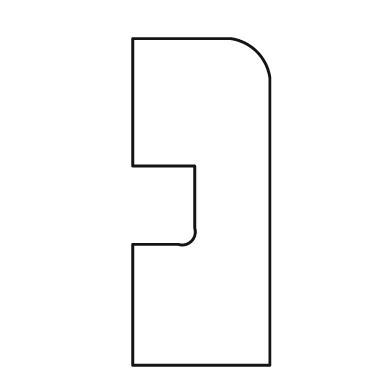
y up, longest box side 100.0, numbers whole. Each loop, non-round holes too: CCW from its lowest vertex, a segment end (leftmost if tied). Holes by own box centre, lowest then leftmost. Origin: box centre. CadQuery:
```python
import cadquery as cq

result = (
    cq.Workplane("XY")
    .moveTo(-21.0, -50.0)
    .lineTo(21.0, -50.0)
    .lineTo(21.0, 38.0)
    .threePointArc((17.0, 46.0), (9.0, 50.0))
    .lineTo(-21.0, 50.0)
    .lineTo(-21.0, 11.0)
    .lineTo(-2.0, 11.0)
    .lineTo(-2.0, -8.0)
    .threePointArc((-3.0, -12.0), (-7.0, -13.0))
    .lineTo(-21.0, -13.0)
    .close()
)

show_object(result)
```